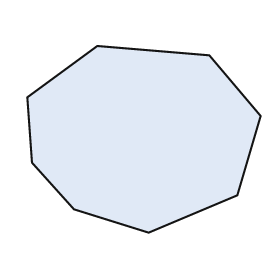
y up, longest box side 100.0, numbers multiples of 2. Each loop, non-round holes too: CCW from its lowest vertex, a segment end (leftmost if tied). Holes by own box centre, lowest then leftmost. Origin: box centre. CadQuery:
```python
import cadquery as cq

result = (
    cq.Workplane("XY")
    .moveTo(2.0, -40.0)
    .lineTo(40.0, -24.0)
    .lineTo(50.0, 10.0)
    .lineTo(28.0, 36.0)
    .lineTo(-20.0, 40.0)
    .lineTo(-50.0, 18.0)
    .lineTo(-48.0, -10.0)
    .lineTo(-30.0, -30.0)
    .close()
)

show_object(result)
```